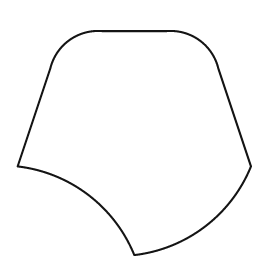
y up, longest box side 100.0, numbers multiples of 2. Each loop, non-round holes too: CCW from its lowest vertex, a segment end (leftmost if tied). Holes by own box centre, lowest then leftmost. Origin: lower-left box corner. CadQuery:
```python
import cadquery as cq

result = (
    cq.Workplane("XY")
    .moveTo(50.0, 0.0)
    .threePointArc((80.0, 12.0), (100.0, 38.0))
    .lineTo(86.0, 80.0)
    .threePointArc((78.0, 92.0), (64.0, 96.0))
    .lineTo(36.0, 96.0)
    .threePointArc((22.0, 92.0), (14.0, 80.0))
    .lineTo(0.0, 38.0)
    .threePointArc((30.0, 26.0), (50.0, 0.0))
    .close()
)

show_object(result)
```